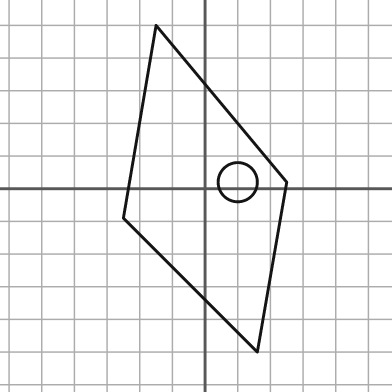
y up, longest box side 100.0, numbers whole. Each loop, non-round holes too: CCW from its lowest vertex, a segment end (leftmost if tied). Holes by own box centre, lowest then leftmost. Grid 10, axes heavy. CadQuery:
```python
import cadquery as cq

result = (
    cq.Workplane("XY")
    .moveTo(16.0, -50.0)
    .lineTo(25.0, 2.0)
    .lineTo(-15.0, 50.0)
    .lineTo(-25.0, -9.0)
    .close()
    .moveTo(10.0, 2.0)
    .circle(6.0)
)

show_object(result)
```